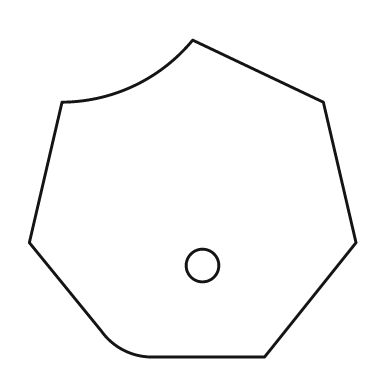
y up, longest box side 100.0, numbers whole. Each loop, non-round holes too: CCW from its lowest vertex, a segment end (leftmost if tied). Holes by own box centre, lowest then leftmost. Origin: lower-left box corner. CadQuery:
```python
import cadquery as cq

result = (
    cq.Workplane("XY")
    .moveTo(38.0, 0.0)
    .lineTo(72.0, 0.0)
    .lineTo(100.0, 35.0)
    .lineTo(90.0, 78.0)
    .lineTo(50.0, 97.0)
    .threePointArc((32.0, 83.0), (10.0, 78.0))
    .lineTo(0.0, 35.0)
    .lineTo(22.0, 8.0)
    .threePointArc((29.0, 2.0), (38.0, 0.0))
    .close()
    .moveTo(53.0, 28.0)
    .circle(5.0)
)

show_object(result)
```